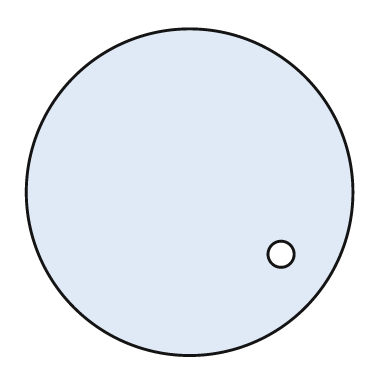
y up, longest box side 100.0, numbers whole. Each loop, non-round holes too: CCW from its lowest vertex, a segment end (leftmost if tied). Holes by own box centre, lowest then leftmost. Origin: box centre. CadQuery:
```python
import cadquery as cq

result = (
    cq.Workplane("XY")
    .moveTo(0.0, 0.0)
    .circle(50.0)
    .moveTo(28.0, -19.0)
    .circle(4.0)
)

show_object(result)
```